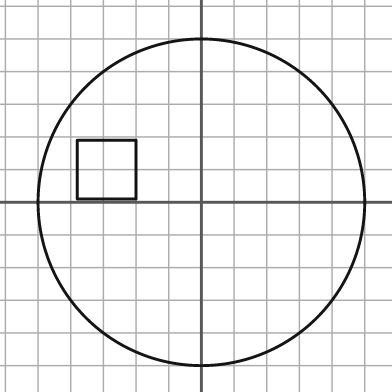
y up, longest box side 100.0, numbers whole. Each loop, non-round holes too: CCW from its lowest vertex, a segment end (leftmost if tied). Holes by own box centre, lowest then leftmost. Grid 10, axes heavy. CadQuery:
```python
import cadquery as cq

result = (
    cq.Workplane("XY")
    .moveTo(0.0, 0.0)
    .circle(50.0)
    .moveTo(-38.0, 1.0)
    .lineTo(-20.0, 1.0)
    .lineTo(-20.0, 19.0)
    .lineTo(-38.0, 19.0)
    .close()
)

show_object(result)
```